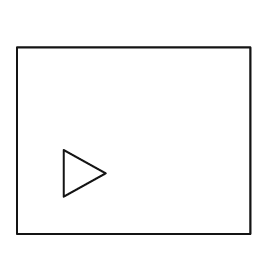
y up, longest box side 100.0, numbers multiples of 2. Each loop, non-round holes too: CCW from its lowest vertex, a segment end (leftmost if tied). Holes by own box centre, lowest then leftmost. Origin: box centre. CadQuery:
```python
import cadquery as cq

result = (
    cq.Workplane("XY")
    .moveTo(-50.0, -40.0)
    .lineTo(50.0, -40.0)
    .lineTo(50.0, 40.0)
    .lineTo(-50.0, 40.0)
    .close()
    .moveTo(-30.0, -24.0)
    .lineTo(-12.0, -14.0)
    .lineTo(-30.0, -4.0)
    .close()
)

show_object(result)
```